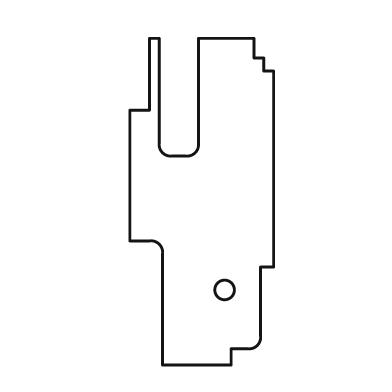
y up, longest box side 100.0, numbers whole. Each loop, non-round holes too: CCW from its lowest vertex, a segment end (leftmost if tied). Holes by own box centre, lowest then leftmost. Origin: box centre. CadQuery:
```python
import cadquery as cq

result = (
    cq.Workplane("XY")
    .moveTo(-12.0, -50.0)
    .lineTo(9.0, -50.0)
    .lineTo(9.0, -45.0)
    .lineTo(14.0, -45.0)
    .threePointArc((17.0, -44.0), (18.0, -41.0))
    .lineTo(18.0, -20.0)
    .lineTo(22.0, -20.0)
    .lineTo(22.0, 40.0)
    .lineTo(19.0, 40.0)
    .lineTo(19.0, 44.0)
    .lineTo(16.0, 44.0)
    .lineTo(16.0, 50.0)
    .lineTo(-1.0, 50.0)
    .lineTo(-1.0, 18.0)
    .threePointArc((-2.0, 15.0), (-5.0, 14.0))
    .lineTo(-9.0, 14.0)
    .threePointArc((-12.0, 15.0), (-13.0, 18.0))
    .lineTo(-13.0, 50.0)
    .lineTo(-16.0, 50.0)
    .lineTo(-16.0, 28.0)
    .lineTo(-22.0, 28.0)
    .lineTo(-22.0, -12.0)
    .lineTo(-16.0, -12.0)
    .threePointArc((-13.0, -13.0), (-12.0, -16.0))
    .close()
    .moveTo(7.0, -27.0)
    .circle(3.0)
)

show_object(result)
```